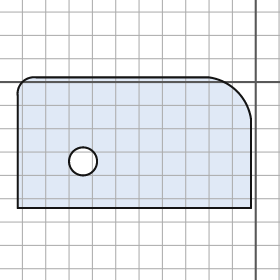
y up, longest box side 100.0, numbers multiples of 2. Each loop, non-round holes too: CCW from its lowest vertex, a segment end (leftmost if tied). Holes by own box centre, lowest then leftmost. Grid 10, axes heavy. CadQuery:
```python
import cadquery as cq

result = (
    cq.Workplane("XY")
    .moveTo(-102.0, -54.0)
    .lineTo(-2.0, -54.0)
    .lineTo(-2.0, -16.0)
    .threePointArc((-8.0, -4.0), (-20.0, 2.0))
    .lineTo(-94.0, 2.0)
    .threePointArc((-100.0, 0.0), (-102.0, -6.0))
    .close()
    .moveTo(-74.0, -34.0)
    .circle(6.0)
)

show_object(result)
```